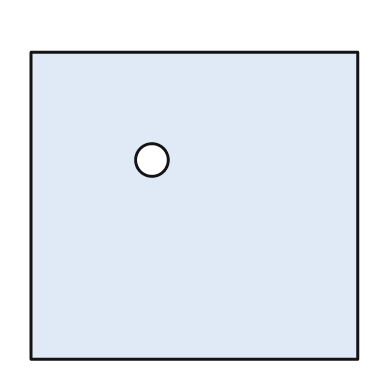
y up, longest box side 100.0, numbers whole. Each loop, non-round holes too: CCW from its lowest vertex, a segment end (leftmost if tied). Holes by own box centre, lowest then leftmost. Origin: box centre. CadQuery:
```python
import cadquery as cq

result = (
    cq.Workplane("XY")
    .moveTo(-50.0, -47.0)
    .lineTo(50.0, -47.0)
    .lineTo(50.0, 47.0)
    .lineTo(-50.0, 47.0)
    .close()
    .moveTo(-13.0, 14.0)
    .circle(5.0)
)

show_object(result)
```